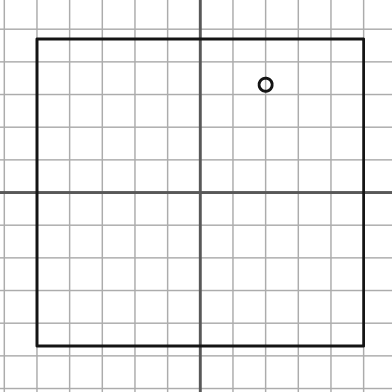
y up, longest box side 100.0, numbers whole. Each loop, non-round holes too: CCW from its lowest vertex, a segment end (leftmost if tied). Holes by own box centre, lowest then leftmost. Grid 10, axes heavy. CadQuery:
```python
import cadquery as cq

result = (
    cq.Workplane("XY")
    .moveTo(-50.0, -47.0)
    .lineTo(50.0, -47.0)
    .lineTo(50.0, 47.0)
    .lineTo(-50.0, 47.0)
    .close()
    .moveTo(20.0, 33.0)
    .circle(2.0)
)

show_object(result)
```